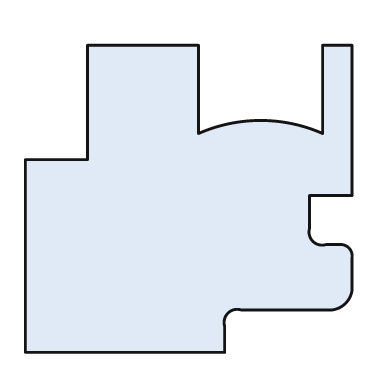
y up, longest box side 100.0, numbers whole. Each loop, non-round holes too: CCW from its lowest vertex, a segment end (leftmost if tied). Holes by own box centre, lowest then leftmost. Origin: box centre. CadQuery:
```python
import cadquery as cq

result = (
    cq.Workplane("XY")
    .moveTo(-50.0, -47.0)
    .lineTo(11.0, -47.0)
    .lineTo(11.0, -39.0)
    .threePointArc((12.0, -35.0), (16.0, -34.0))
    .lineTo(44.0, -34.0)
    .threePointArc((48.0, -32.0), (50.0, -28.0))
    .lineTo(50.0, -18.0)
    .threePointArc((49.0, -15.0), (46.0, -14.0))
    .lineTo(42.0, -14.0)
    .threePointArc((38.0, -13.0), (37.0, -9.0))
    .lineTo(37.0, 1.0)
    .lineTo(50.0, 1.0)
    .lineTo(50.0, 47.0)
    .lineTo(41.0, 47.0)
    .lineTo(41.0, 20.0)
    .threePointArc((22.0, 24.0), (3.0, 20.0))
    .lineTo(3.0, 47.0)
    .lineTo(-31.0, 47.0)
    .lineTo(-31.0, 12.0)
    .lineTo(-50.0, 12.0)
    .close()
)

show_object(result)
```